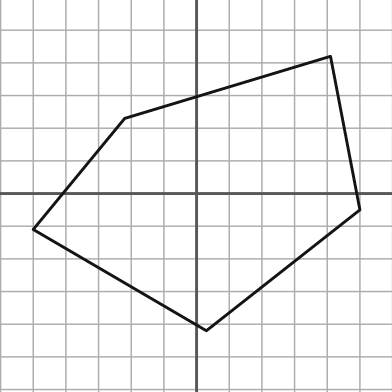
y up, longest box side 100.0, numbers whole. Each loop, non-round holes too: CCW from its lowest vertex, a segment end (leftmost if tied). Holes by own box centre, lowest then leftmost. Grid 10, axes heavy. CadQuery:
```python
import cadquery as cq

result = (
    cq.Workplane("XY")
    .moveTo(3.0, -42.0)
    .lineTo(50.0, -5.0)
    .lineTo(41.0, 42.0)
    .lineTo(-22.0, 23.0)
    .lineTo(-50.0, -11.0)
    .close()
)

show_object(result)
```